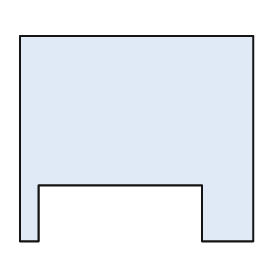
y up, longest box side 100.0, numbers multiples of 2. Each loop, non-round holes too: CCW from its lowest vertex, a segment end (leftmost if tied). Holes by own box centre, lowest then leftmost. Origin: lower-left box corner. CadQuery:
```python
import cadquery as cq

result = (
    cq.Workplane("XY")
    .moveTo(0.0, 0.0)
    .lineTo(8.0, 0.0)
    .lineTo(8.0, 24.0)
    .lineTo(78.0, 24.0)
    .lineTo(78.0, 0.0)
    .lineTo(100.0, 0.0)
    .lineTo(100.0, 88.0)
    .lineTo(0.0, 88.0)
    .close()
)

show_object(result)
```